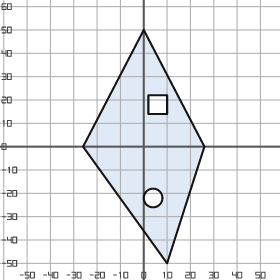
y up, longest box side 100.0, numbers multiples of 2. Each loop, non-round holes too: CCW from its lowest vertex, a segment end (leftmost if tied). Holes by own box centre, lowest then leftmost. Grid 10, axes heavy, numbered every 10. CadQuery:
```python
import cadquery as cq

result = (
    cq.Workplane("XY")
    .moveTo(10.0, -50.0)
    .lineTo(26.0, 0.0)
    .lineTo(0.0, 50.0)
    .lineTo(-26.0, 0.0)
    .close()
    .moveTo(4.0, -22.0)
    .circle(4.0)
    .moveTo(2.0, 14.0)
    .lineTo(10.0, 14.0)
    .lineTo(10.0, 22.0)
    .lineTo(2.0, 22.0)
    .close()
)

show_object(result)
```